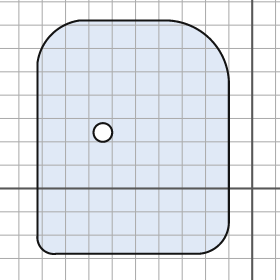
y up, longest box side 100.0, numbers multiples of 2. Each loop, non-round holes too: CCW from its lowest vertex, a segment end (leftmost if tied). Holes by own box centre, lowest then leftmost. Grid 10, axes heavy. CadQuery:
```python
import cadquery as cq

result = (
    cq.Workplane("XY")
    .moveTo(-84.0, -28.0)
    .lineTo(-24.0, -28.0)
    .threePointArc((-14.0, -24.0), (-10.0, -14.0))
    .lineTo(-10.0, 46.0)
    .threePointArc((-18.0, 64.0), (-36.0, 72.0))
    .lineTo(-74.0, 72.0)
    .threePointArc((-86.0, 66.0), (-92.0, 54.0))
    .lineTo(-92.0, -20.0)
    .threePointArc((-90.0, -26.0), (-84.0, -28.0))
    .close()
    .moveTo(-64.0, 24.0)
    .circle(4.0)
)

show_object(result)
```